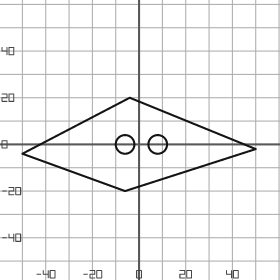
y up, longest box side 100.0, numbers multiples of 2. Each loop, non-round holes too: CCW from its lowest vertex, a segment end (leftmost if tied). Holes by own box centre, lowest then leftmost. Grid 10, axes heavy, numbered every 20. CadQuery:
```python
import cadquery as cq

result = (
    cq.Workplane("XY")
    .moveTo(-6.0, -20.0)
    .lineTo(50.0, -2.0)
    .lineTo(-4.0, 20.0)
    .lineTo(-50.0, -4.0)
    .close()
    .moveTo(-6.0, 0.0)
    .circle(4.0)
    .moveTo(8.0, 0.0)
    .circle(4.0)
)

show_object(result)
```